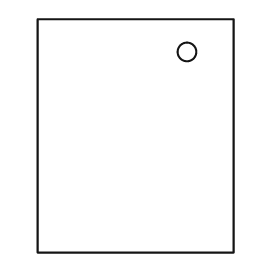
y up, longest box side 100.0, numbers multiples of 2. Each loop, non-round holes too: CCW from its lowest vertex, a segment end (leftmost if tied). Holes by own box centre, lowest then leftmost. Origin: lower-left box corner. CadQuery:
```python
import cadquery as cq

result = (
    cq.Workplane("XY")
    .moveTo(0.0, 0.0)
    .lineTo(84.0, 0.0)
    .lineTo(84.0, 100.0)
    .lineTo(0.0, 100.0)
    .close()
    .moveTo(64.0, 86.0)
    .circle(4.0)
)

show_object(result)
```